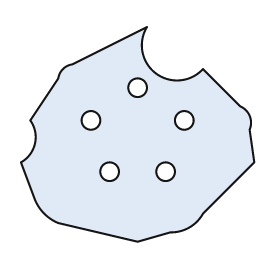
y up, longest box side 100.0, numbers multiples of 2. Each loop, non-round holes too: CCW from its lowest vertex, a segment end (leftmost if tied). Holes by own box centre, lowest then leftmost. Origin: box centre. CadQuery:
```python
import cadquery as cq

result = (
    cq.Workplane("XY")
    .moveTo(0.0, -46.0)
    .lineTo(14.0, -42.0)
    .threePointArc((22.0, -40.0), (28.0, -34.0))
    .lineTo(50.0, -12.0)
    .lineTo(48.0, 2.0)
    .threePointArc((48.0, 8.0), (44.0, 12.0))
    .lineTo(28.0, 28.0)
    .threePointArc((8.0, 26.0), (4.0, 46.0))
    .lineTo(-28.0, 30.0)
    .threePointArc((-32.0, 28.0), (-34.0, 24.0))
    .lineTo(-46.0, 6.0)
    .threePointArc((-44.0, -4.0), (-50.0, -12.0))
    .lineTo(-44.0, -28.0)
    .threePointArc((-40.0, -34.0), (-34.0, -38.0))
    .close()
    .moveTo(-12.0, -16.0)
    .circle(4.0)
    .moveTo(12.0, -16.0)
    .circle(4.0)
    .moveTo(-20.0, 6.0)
    .circle(4.0)
    .moveTo(20.0, 6.0)
    .circle(4.0)
    .moveTo(0.0, 20.0)
    .circle(4.0)
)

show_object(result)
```